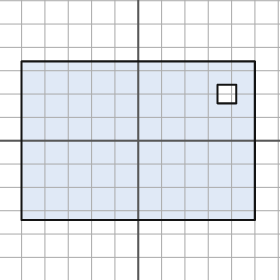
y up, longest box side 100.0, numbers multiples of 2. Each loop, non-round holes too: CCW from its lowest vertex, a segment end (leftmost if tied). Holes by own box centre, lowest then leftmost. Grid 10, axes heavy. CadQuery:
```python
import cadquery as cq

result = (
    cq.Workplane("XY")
    .moveTo(-50.0, -34.0)
    .lineTo(50.0, -34.0)
    .lineTo(50.0, 34.0)
    .lineTo(-50.0, 34.0)
    .close()
    .moveTo(34.0, 16.0)
    .lineTo(42.0, 16.0)
    .lineTo(42.0, 24.0)
    .lineTo(34.0, 24.0)
    .close()
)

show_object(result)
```